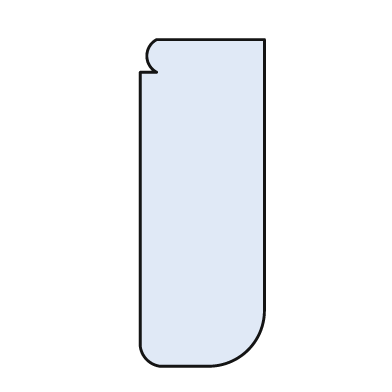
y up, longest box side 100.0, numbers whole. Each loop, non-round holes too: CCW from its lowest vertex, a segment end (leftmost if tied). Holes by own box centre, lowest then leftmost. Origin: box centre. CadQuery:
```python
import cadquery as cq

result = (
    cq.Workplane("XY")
    .moveTo(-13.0, -50.0)
    .lineTo(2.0, -50.0)
    .threePointArc((14.0, -45.0), (19.0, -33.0))
    .lineTo(19.0, 50.0)
    .lineTo(-14.0, 50.0)
    .threePointArc((-17.0, 45.0), (-14.0, 40.0))
    .lineTo(-19.0, 40.0)
    .lineTo(-19.0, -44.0)
    .threePointArc((-17.0, -48.0), (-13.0, -50.0))
    .close()
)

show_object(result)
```